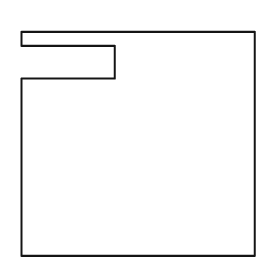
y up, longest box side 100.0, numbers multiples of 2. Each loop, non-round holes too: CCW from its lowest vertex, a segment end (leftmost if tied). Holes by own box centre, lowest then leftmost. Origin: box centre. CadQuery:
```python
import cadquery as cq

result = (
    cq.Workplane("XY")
    .moveTo(-50.0, -48.0)
    .lineTo(50.0, -48.0)
    .lineTo(50.0, 48.0)
    .lineTo(-50.0, 48.0)
    .lineTo(-50.0, 42.0)
    .lineTo(-10.0, 42.0)
    .lineTo(-10.0, 28.0)
    .lineTo(-50.0, 28.0)
    .close()
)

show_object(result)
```